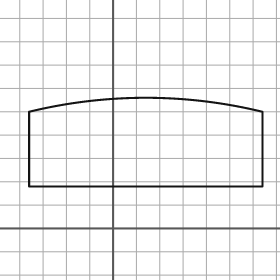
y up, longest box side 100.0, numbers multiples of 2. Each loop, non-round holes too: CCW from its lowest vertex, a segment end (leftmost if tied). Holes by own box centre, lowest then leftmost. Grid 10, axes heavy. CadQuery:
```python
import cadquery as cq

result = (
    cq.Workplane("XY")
    .moveTo(-36.0, 18.0)
    .lineTo(64.0, 18.0)
    .lineTo(64.0, 50.0)
    .threePointArc((14.0, 56.0), (-36.0, 50.0))
    .close()
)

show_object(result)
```